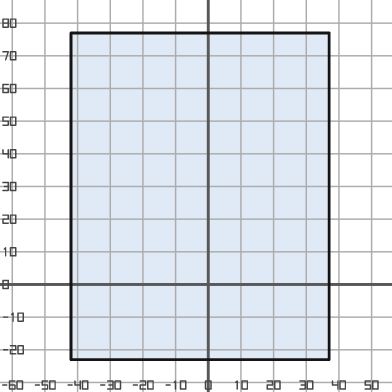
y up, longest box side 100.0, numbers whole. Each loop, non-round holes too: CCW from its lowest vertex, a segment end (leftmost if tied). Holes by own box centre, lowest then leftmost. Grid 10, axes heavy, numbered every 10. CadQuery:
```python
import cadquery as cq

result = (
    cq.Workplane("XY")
    .moveTo(-42.0, -23.0)
    .lineTo(37.0, -23.0)
    .lineTo(37.0, 77.0)
    .lineTo(-42.0, 77.0)
    .close()
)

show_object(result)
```